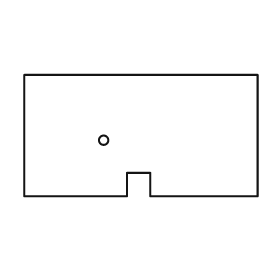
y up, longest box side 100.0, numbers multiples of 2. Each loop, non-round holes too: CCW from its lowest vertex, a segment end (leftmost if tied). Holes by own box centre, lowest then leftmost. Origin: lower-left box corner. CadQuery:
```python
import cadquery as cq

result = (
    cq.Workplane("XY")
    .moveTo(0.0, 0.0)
    .lineTo(44.0, 0.0)
    .lineTo(44.0, 10.0)
    .lineTo(54.0, 10.0)
    .lineTo(54.0, 0.0)
    .lineTo(100.0, 0.0)
    .lineTo(100.0, 52.0)
    .lineTo(0.0, 52.0)
    .close()
    .moveTo(34.0, 24.0)
    .circle(2.0)
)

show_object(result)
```